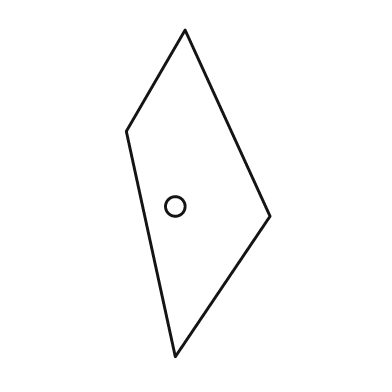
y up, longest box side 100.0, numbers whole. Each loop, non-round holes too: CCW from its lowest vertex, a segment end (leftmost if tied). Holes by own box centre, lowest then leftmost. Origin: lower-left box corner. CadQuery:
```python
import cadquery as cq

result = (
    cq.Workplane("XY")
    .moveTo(15.0, 0.0)
    .lineTo(44.0, 43.0)
    .lineTo(18.0, 100.0)
    .lineTo(0.0, 69.0)
    .close()
    .moveTo(15.0, 46.0)
    .circle(3.0)
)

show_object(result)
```